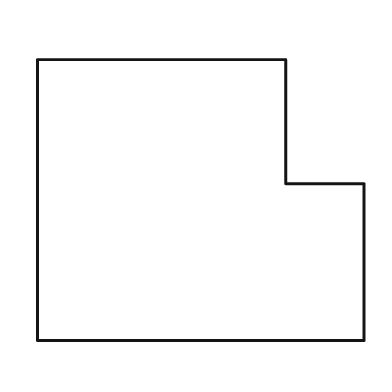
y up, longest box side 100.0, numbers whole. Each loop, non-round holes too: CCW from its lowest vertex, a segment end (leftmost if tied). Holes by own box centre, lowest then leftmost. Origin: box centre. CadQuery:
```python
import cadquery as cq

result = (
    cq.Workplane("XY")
    .moveTo(-50.0, -43.0)
    .lineTo(50.0, -43.0)
    .lineTo(50.0, 5.0)
    .lineTo(26.0, 5.0)
    .lineTo(26.0, 43.0)
    .lineTo(-50.0, 43.0)
    .close()
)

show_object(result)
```